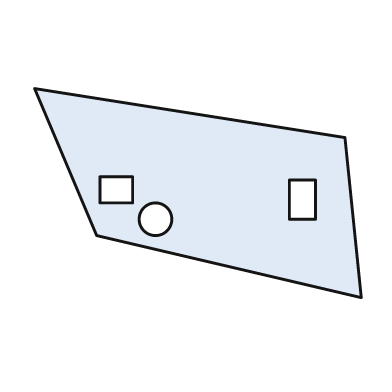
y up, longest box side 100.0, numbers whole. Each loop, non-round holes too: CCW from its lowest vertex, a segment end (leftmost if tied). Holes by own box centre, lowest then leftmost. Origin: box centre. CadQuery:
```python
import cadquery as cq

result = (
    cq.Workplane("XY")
    .moveTo(50.0, -32.0)
    .lineTo(45.0, 17.0)
    .lineTo(-50.0, 32.0)
    .lineTo(-31.0, -13.0)
    .close()
    .moveTo(-13.0, -8.0)
    .circle(5.0)
    .moveTo(28.0, -8.0)
    .lineTo(36.0, -8.0)
    .lineTo(36.0, 4.0)
    .lineTo(28.0, 4.0)
    .close()
    .moveTo(-30.0, -3.0)
    .lineTo(-20.0, -3.0)
    .lineTo(-20.0, 5.0)
    .lineTo(-30.0, 5.0)
    .close()
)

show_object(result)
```